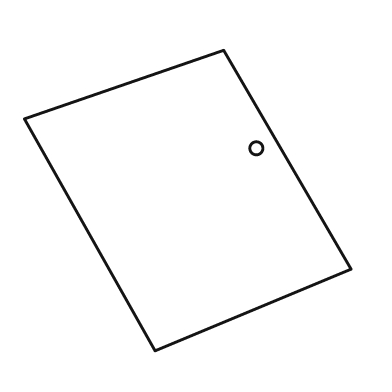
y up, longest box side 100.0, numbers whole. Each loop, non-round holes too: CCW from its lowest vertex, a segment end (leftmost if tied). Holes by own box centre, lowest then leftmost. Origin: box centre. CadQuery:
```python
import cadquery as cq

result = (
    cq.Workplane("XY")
    .moveTo(-10.0, -46.0)
    .lineTo(50.0, -21.0)
    .lineTo(11.0, 46.0)
    .lineTo(-50.0, 25.0)
    .close()
    .moveTo(21.0, 16.0)
    .circle(2.0)
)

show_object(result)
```